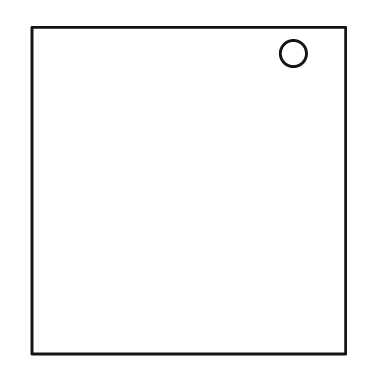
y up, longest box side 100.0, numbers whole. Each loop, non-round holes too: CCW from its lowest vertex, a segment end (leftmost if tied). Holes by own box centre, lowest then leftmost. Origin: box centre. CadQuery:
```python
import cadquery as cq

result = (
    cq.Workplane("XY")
    .moveTo(-48.0, -50.0)
    .lineTo(48.0, -50.0)
    .lineTo(48.0, 50.0)
    .lineTo(-48.0, 50.0)
    .close()
    .moveTo(32.0, 42.0)
    .circle(4.0)
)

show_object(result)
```